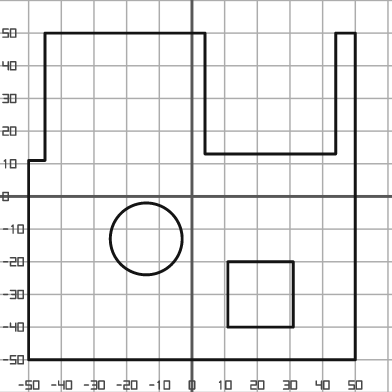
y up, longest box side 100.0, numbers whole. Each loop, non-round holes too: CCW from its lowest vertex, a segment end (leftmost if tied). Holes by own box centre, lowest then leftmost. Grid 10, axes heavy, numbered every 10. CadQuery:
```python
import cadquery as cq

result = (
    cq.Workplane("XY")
    .moveTo(-50.0, -50.0)
    .lineTo(50.0, -50.0)
    .lineTo(50.0, 50.0)
    .lineTo(44.0, 50.0)
    .lineTo(44.0, 13.0)
    .lineTo(4.0, 13.0)
    .lineTo(4.0, 50.0)
    .lineTo(-45.0, 50.0)
    .lineTo(-45.0, 11.0)
    .lineTo(-50.0, 11.0)
    .close()
    .moveTo(11.0, -40.0)
    .lineTo(31.0, -40.0)
    .lineTo(31.0, -20.0)
    .lineTo(11.0, -20.0)
    .close()
    .moveTo(-14.0, -13.0)
    .circle(11.0)
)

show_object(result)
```